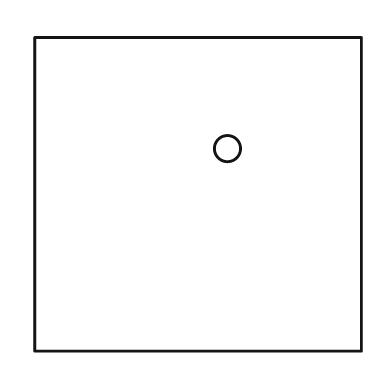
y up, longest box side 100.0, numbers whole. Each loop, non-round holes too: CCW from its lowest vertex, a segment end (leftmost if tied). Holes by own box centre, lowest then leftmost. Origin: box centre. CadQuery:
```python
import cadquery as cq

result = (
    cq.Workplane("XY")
    .moveTo(-50.0, -48.0)
    .lineTo(50.0, -48.0)
    .lineTo(50.0, 48.0)
    .lineTo(-50.0, 48.0)
    .close()
    .moveTo(9.0, 14.0)
    .circle(4.0)
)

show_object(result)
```